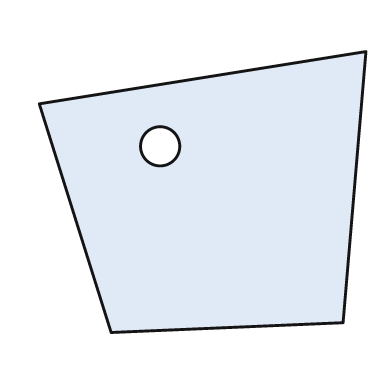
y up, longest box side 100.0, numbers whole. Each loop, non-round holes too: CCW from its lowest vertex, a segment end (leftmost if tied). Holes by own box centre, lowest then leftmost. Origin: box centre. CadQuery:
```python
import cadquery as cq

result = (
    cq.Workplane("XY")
    .moveTo(-28.0, -43.0)
    .lineTo(43.0, -40.0)
    .lineTo(50.0, 43.0)
    .lineTo(-50.0, 27.0)
    .close()
    .moveTo(-13.0, 14.0)
    .circle(6.0)
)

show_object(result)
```